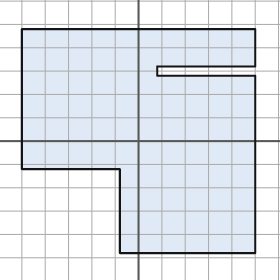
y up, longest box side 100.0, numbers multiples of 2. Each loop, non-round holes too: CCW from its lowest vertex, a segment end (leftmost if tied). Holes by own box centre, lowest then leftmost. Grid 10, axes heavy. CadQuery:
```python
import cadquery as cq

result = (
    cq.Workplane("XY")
    .moveTo(-8.0, -48.0)
    .lineTo(50.0, -48.0)
    .lineTo(50.0, 28.0)
    .lineTo(8.0, 28.0)
    .lineTo(8.0, 32.0)
    .lineTo(50.0, 32.0)
    .lineTo(50.0, 48.0)
    .lineTo(-50.0, 48.0)
    .lineTo(-50.0, -12.0)
    .lineTo(-8.0, -12.0)
    .close()
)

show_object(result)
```